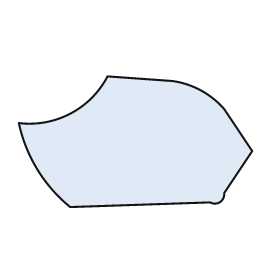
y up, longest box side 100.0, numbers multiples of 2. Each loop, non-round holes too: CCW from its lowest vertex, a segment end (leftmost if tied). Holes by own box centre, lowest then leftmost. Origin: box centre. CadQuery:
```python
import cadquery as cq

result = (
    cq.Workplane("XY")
    .moveTo(-28.0, -28.0)
    .lineTo(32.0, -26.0)
    .threePointArc((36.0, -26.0), (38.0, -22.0))
    .lineTo(50.0, -4.0)
    .lineTo(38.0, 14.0)
    .threePointArc((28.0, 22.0), (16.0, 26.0))
    .lineTo(-12.0, 28.0)
    .threePointArc((-28.0, 12.0), (-50.0, 8.0))
    .threePointArc((-42.0, -12.0), (-28.0, -28.0))
    .close()
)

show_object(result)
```